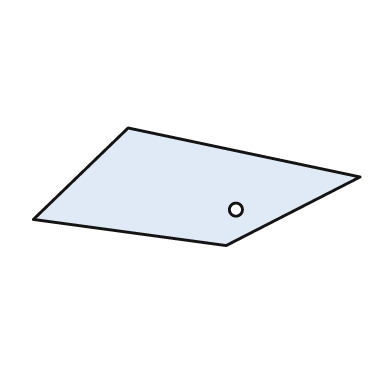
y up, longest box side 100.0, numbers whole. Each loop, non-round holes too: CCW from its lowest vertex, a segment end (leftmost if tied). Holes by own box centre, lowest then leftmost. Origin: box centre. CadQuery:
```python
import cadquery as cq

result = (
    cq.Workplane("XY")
    .moveTo(9.0, -18.0)
    .lineTo(50.0, 3.0)
    .lineTo(-21.0, 18.0)
    .lineTo(-50.0, -10.0)
    .close()
    .moveTo(12.0, -7.0)
    .circle(2.0)
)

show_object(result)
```